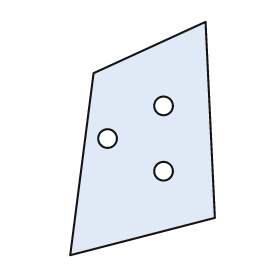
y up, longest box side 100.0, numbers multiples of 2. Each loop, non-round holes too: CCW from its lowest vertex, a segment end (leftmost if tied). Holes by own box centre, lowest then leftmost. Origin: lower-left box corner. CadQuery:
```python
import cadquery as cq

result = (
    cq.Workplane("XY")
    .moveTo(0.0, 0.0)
    .lineTo(62.0, 16.0)
    .lineTo(58.0, 100.0)
    .lineTo(10.0, 78.0)
    .close()
    .moveTo(40.0, 36.0)
    .circle(4.0)
    .moveTo(16.0, 50.0)
    .circle(4.0)
    .moveTo(40.0, 64.0)
    .circle(4.0)
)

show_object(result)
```